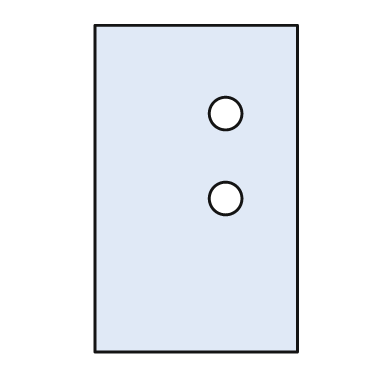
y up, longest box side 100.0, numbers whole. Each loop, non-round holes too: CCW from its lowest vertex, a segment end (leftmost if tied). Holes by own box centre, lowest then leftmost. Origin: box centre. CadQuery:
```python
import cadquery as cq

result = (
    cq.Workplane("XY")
    .moveTo(-31.0, -50.0)
    .lineTo(31.0, -50.0)
    .lineTo(31.0, 50.0)
    .lineTo(-31.0, 50.0)
    .close()
    .moveTo(9.0, -3.0)
    .circle(5.0)
    .moveTo(9.0, 23.0)
    .circle(5.0)
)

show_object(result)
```